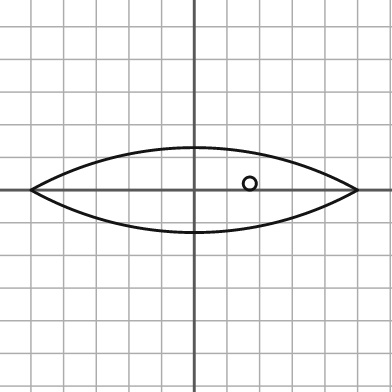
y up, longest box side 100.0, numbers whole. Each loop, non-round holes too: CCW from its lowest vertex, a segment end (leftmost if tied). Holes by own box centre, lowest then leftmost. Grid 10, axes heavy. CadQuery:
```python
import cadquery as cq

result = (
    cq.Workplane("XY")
    .moveTo(-50.0, 0.0)
    .threePointArc((0.0, -13.0), (50.0, 0.0))
    .threePointArc((0.0, 13.0), (-50.0, 0.0))
    .close()
    .moveTo(17.0, 2.0)
    .circle(2.0)
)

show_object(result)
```